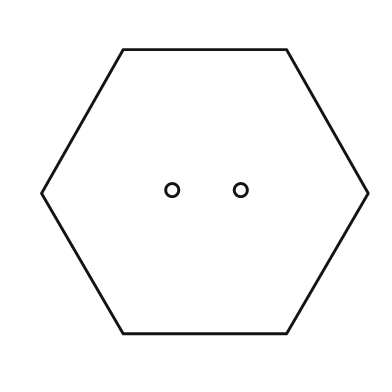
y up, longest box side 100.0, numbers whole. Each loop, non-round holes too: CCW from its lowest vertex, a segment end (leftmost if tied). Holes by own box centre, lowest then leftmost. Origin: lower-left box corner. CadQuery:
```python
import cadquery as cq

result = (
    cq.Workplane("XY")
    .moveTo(25.0, 0.0)
    .lineTo(75.0, 0.0)
    .lineTo(100.0, 43.0)
    .lineTo(75.0, 87.0)
    .lineTo(25.0, 87.0)
    .lineTo(0.0, 43.0)
    .close()
    .moveTo(40.0, 44.0)
    .circle(2.0)
    .moveTo(61.0, 44.0)
    .circle(2.0)
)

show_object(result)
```